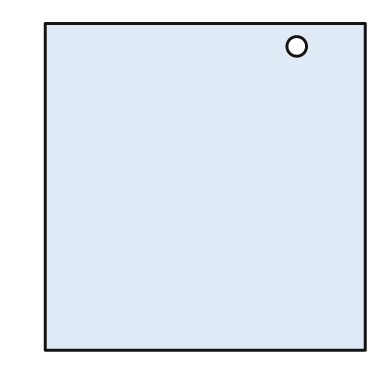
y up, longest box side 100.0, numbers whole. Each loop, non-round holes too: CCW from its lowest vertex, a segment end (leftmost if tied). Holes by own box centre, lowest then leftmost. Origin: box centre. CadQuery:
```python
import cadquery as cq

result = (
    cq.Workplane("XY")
    .moveTo(-49.0, -50.0)
    .lineTo(49.0, -50.0)
    .lineTo(49.0, 50.0)
    .lineTo(-49.0, 50.0)
    .close()
    .moveTo(28.0, 43.0)
    .circle(3.0)
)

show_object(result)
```